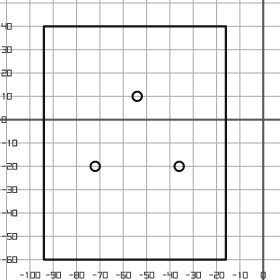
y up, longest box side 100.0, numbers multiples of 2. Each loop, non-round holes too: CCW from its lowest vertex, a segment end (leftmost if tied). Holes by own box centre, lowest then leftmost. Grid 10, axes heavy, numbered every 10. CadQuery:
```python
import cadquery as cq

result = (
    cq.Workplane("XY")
    .moveTo(-94.0, -60.0)
    .lineTo(-16.0, -60.0)
    .lineTo(-16.0, 40.0)
    .lineTo(-94.0, 40.0)
    .close()
    .moveTo(-72.0, -20.0)
    .circle(2.0)
    .moveTo(-36.0, -20.0)
    .circle(2.0)
    .moveTo(-54.0, 10.0)
    .circle(2.0)
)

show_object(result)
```